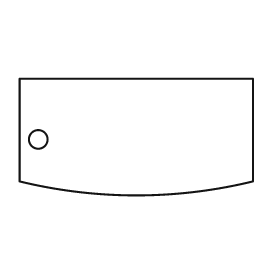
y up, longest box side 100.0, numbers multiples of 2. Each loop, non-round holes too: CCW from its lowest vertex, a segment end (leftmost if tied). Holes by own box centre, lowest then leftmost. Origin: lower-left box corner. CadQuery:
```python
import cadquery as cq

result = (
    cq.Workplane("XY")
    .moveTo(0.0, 6.0)
    .threePointArc((50.0, 0.0), (100.0, 6.0))
    .lineTo(100.0, 50.0)
    .lineTo(0.0, 50.0)
    .close()
    .moveTo(8.0, 24.0)
    .circle(4.0)
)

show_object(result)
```